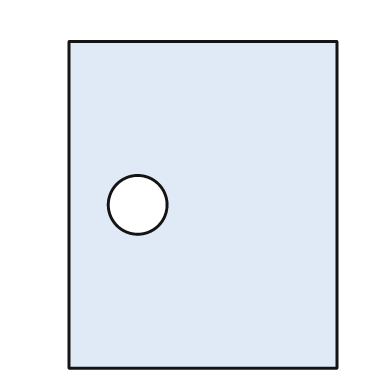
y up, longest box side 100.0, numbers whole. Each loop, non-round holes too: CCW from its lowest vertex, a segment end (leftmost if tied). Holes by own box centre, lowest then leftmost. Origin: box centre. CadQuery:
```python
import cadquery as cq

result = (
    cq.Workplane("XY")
    .moveTo(-41.0, -50.0)
    .lineTo(41.0, -50.0)
    .lineTo(41.0, 50.0)
    .lineTo(-41.0, 50.0)
    .close()
    .moveTo(-20.0, 0.0)
    .circle(9.0)
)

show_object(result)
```